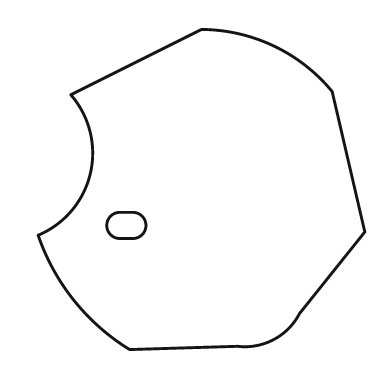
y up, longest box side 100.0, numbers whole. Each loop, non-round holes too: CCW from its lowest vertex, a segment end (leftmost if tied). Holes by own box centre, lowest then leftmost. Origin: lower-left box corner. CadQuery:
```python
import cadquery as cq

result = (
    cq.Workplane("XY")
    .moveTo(28.0, 0.0)
    .lineTo(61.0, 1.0)
    .threePointArc((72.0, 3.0), (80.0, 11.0))
    .lineTo(100.0, 36.0)
    .lineTo(90.0, 79.0)
    .threePointArc((72.0, 93.0), (50.0, 98.0))
    .lineTo(10.0, 78.0)
    .threePointArc((16.0, 54.0), (0.0, 35.0))
    .threePointArc((11.0, 15.0), (28.0, 0.0))
    .close()
    .moveTo(25.0, 34.0)
    .lineTo(29.0, 34.0)
    .threePointArc((33.0, 38.0), (29.0, 42.0))
    .lineTo(25.0, 42.0)
    .threePointArc((21.0, 38.0), (25.0, 34.0))
    .close()
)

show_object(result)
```